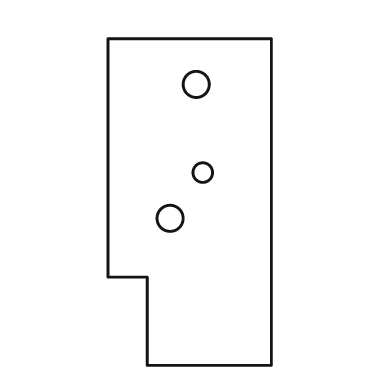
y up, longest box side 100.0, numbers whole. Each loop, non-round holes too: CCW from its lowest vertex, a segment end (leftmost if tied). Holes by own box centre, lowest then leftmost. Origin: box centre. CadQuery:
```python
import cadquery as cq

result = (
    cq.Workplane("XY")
    .moveTo(-13.0, -50.0)
    .lineTo(25.0, -50.0)
    .lineTo(25.0, 50.0)
    .lineTo(-25.0, 50.0)
    .lineTo(-25.0, -23.0)
    .lineTo(-13.0, -23.0)
    .close()
    .moveTo(-6.0, -5.0)
    .circle(4.0)
    .moveTo(4.0, 9.0)
    .circle(3.0)
    .moveTo(2.0, 36.0)
    .circle(4.0)
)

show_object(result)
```